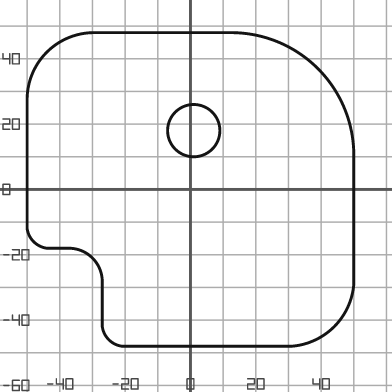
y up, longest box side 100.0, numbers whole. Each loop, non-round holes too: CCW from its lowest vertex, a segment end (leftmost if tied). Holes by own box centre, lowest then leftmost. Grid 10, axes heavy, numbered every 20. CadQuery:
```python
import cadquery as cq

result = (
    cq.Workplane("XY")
    .moveTo(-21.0, -48.0)
    .lineTo(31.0, -48.0)
    .threePointArc((44.0, -42.0), (50.0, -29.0))
    .lineTo(50.0, 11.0)
    .threePointArc((39.0, 37.0), (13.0, 48.0))
    .lineTo(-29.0, 48.0)
    .threePointArc((-44.0, 42.0), (-50.0, 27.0))
    .lineTo(-50.0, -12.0)
    .threePointArc((-48.0, -16.0), (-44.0, -18.0))
    .lineTo(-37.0, -18.0)
    .threePointArc((-30.0, -21.0), (-27.0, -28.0))
    .lineTo(-27.0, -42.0)
    .threePointArc((-25.0, -46.0), (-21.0, -48.0))
    .close()
    .moveTo(1.0, 18.0)
    .circle(8.0)
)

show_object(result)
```